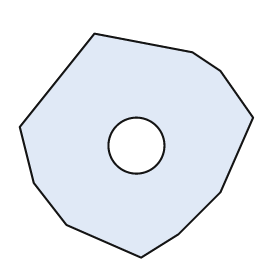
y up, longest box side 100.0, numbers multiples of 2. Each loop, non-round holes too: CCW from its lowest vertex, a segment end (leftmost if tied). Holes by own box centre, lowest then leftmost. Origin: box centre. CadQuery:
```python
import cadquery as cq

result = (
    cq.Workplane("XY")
    .moveTo(2.0, -48.0)
    .lineTo(18.0, -38.0)
    .lineTo(36.0, -20.0)
    .lineTo(50.0, 12.0)
    .lineTo(36.0, 32.0)
    .lineTo(24.0, 40.0)
    .lineTo(-18.0, 48.0)
    .lineTo(-50.0, 8.0)
    .lineTo(-44.0, -16.0)
    .lineTo(-30.0, -34.0)
    .close()
    .moveTo(0.0, 0.0)
    .circle(12.0)
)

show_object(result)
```